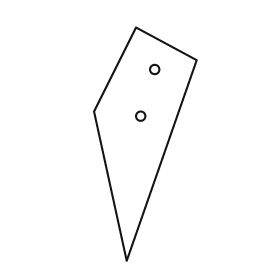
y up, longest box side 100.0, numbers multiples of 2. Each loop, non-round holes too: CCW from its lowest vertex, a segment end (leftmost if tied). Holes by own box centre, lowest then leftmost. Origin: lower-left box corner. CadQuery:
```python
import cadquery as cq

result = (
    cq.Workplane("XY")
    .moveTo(14.0, 0.0)
    .lineTo(44.0, 86.0)
    .lineTo(18.0, 100.0)
    .lineTo(0.0, 64.0)
    .close()
    .moveTo(20.0, 62.0)
    .circle(2.0)
    .moveTo(26.0, 82.0)
    .circle(2.0)
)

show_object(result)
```